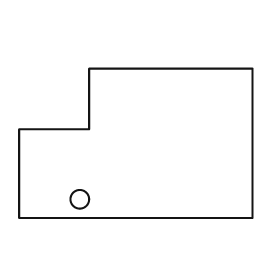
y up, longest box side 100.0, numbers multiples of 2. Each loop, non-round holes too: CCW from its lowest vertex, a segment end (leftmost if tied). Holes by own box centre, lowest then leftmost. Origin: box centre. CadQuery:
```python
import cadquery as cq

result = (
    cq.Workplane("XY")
    .moveTo(-50.0, -32.0)
    .lineTo(50.0, -32.0)
    .lineTo(50.0, 32.0)
    .lineTo(-20.0, 32.0)
    .lineTo(-20.0, 6.0)
    .lineTo(-50.0, 6.0)
    .close()
    .moveTo(-24.0, -24.0)
    .circle(4.0)
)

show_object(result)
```